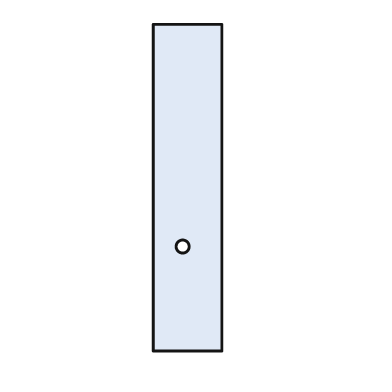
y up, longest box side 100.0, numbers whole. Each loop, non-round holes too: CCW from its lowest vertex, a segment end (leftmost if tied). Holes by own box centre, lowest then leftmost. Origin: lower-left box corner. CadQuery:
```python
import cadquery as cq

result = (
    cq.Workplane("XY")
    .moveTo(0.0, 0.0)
    .lineTo(21.0, 0.0)
    .lineTo(21.0, 100.0)
    .lineTo(0.0, 100.0)
    .close()
    .moveTo(9.0, 32.0)
    .circle(2.0)
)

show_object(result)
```